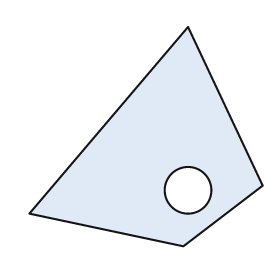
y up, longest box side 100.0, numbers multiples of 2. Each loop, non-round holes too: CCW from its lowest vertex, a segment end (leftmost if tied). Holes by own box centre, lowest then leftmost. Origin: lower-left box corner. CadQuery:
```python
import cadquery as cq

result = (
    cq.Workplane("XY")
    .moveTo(66.0, 0.0)
    .lineTo(100.0, 26.0)
    .lineTo(68.0, 94.0)
    .lineTo(0.0, 14.0)
    .close()
    .moveTo(68.0, 24.0)
    .circle(10.0)
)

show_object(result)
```